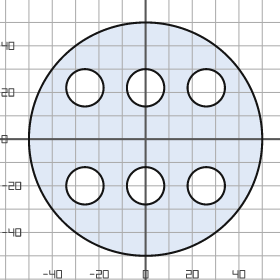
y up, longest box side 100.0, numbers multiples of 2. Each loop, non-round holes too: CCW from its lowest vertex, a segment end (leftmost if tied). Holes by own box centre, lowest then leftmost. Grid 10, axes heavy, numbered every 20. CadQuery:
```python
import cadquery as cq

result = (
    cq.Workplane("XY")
    .moveTo(0.0, 0.0)
    .circle(50.0)
    .moveTo(-26.0, -20.0)
    .circle(8.0)
    .moveTo(0.0, -20.0)
    .circle(8.0)
    .moveTo(26.0, -20.0)
    .circle(8.0)
    .moveTo(-26.0, 22.0)
    .circle(8.0)
    .moveTo(0.0, 22.0)
    .circle(8.0)
    .moveTo(26.0, 22.0)
    .circle(8.0)
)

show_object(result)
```